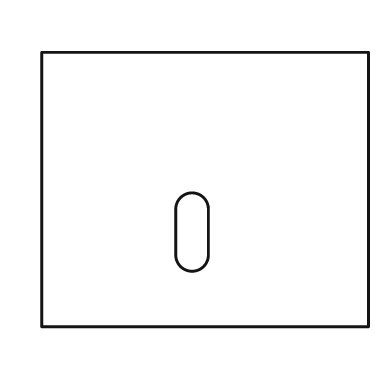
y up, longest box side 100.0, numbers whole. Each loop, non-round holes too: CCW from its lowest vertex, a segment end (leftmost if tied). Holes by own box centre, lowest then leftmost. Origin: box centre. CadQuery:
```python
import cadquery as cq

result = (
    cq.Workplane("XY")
    .moveTo(-50.0, -42.0)
    .lineTo(50.0, -42.0)
    .lineTo(50.0, 42.0)
    .lineTo(-50.0, 42.0)
    .close()
    .moveTo(-9.0, -20.0)
    .threePointArc((-4.0, -25.0), (1.0, -20.0))
    .lineTo(1.0, -6.0)
    .threePointArc((-4.0, -1.0), (-9.0, -6.0))
    .close()
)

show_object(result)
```